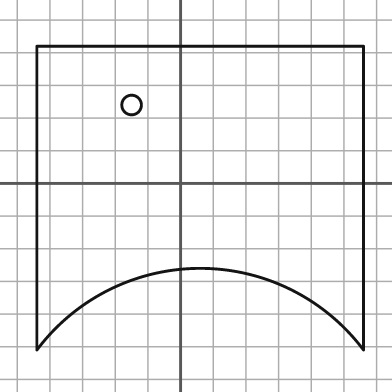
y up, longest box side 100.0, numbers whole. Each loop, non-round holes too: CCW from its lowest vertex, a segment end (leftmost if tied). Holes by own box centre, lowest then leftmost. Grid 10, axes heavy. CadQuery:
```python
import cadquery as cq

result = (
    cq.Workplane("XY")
    .moveTo(-44.0, -51.0)
    .threePointArc((6.0, -26.0), (56.0, -51.0))
    .lineTo(56.0, 42.0)
    .lineTo(-44.0, 42.0)
    .close()
    .moveTo(-15.0, 24.0)
    .circle(3.0)
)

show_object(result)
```